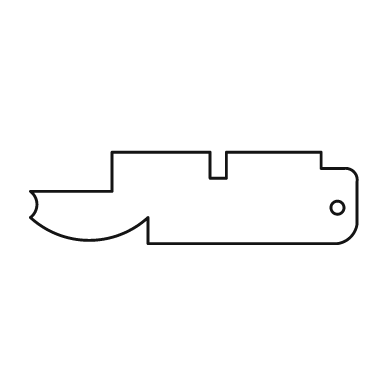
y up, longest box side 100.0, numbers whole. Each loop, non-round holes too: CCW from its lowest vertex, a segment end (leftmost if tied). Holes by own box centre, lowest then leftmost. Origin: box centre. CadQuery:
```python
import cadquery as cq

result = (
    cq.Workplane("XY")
    .moveTo(-14.0, -14.0)
    .lineTo(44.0, -14.0)
    .threePointArc((48.0, -12.0), (50.0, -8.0))
    .lineTo(50.0, 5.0)
    .threePointArc((49.0, 8.0), (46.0, 9.0))
    .lineTo(39.0, 9.0)
    .lineTo(39.0, 14.0)
    .lineTo(10.0, 14.0)
    .lineTo(10.0, 6.0)
    .lineTo(5.0, 6.0)
    .lineTo(5.0, 14.0)
    .lineTo(-25.0, 14.0)
    .lineTo(-25.0, 2.0)
    .lineTo(-50.0, 2.0)
    .threePointArc((-48.0, -2.0), (-50.0, -6.0))
    .threePointArc((-32.0, -13.0), (-14.0, -6.0))
    .close()
    .moveTo(44.0, -3.0)
    .circle(2.0)
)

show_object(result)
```